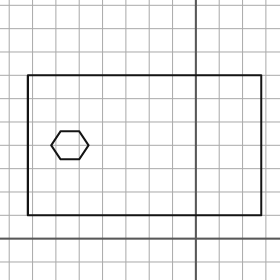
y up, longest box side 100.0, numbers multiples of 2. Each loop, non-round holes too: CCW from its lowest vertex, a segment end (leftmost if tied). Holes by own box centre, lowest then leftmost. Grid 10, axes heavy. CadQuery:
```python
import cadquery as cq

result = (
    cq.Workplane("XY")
    .moveTo(-72.0, 10.0)
    .lineTo(28.0, 10.0)
    .lineTo(28.0, 70.0)
    .lineTo(-72.0, 70.0)
    .close()
    .moveTo(-58.0, 34.0)
    .lineTo(-50.0, 34.0)
    .lineTo(-46.0, 40.0)
    .lineTo(-50.0, 46.0)
    .lineTo(-58.0, 46.0)
    .lineTo(-62.0, 40.0)
    .close()
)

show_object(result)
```